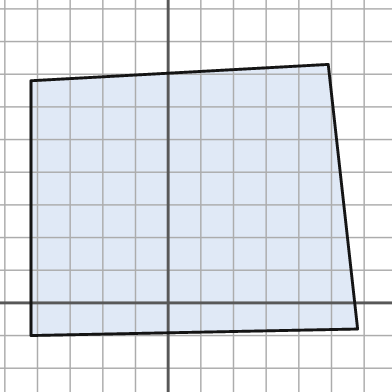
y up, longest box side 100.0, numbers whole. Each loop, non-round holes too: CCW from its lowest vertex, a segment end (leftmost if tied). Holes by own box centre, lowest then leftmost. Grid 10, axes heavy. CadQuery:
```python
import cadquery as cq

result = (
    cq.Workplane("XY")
    .moveTo(-42.0, -10.0)
    .lineTo(58.0, -8.0)
    .lineTo(49.0, 73.0)
    .lineTo(-42.0, 68.0)
    .close()
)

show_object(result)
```